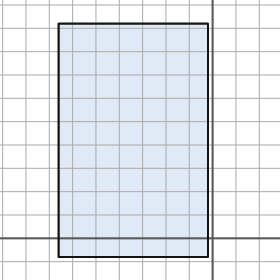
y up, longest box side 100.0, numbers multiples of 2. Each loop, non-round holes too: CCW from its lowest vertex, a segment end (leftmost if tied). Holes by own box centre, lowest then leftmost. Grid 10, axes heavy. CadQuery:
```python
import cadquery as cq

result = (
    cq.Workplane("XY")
    .moveTo(-66.0, -8.0)
    .lineTo(-2.0, -8.0)
    .lineTo(-2.0, 92.0)
    .lineTo(-66.0, 92.0)
    .close()
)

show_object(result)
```